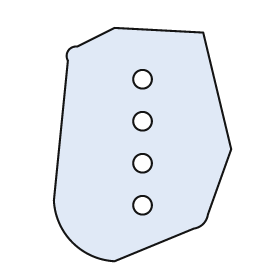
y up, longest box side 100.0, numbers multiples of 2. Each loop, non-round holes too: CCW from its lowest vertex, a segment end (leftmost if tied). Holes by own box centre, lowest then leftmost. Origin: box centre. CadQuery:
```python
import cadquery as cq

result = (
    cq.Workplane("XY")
    .moveTo(-12.0, -50.0)
    .lineTo(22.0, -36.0)
    .threePointArc((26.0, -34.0), (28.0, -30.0))
    .lineTo(38.0, -2.0)
    .lineTo(26.0, 48.0)
    .lineTo(-12.0, 50.0)
    .lineTo(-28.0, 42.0)
    .threePointArc((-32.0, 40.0), (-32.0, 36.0))
    .lineTo(-38.0, -24.0)
    .threePointArc((-30.0, -42.0), (-12.0, -50.0))
    .close()
    .moveTo(0.0, -26.0)
    .circle(4.0)
    .moveTo(0.0, -8.0)
    .circle(4.0)
    .moveTo(0.0, 10.0)
    .circle(4.0)
    .moveTo(0.0, 28.0)
    .circle(4.0)
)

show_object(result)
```